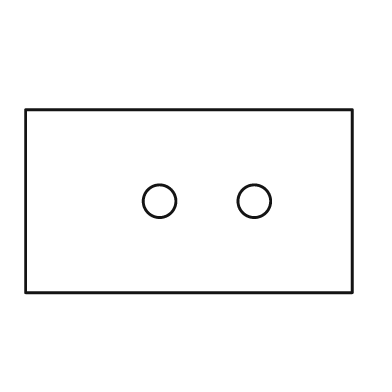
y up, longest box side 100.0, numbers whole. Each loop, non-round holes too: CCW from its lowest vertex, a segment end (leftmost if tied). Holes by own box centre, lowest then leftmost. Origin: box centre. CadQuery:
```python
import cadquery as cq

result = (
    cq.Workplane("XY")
    .moveTo(-50.0, -28.0)
    .lineTo(50.0, -28.0)
    .lineTo(50.0, 28.0)
    .lineTo(-50.0, 28.0)
    .close()
    .moveTo(-9.0, 0.0)
    .circle(5.0)
    .moveTo(20.0, 0.0)
    .circle(5.0)
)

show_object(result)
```